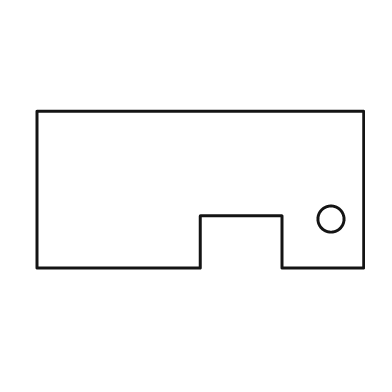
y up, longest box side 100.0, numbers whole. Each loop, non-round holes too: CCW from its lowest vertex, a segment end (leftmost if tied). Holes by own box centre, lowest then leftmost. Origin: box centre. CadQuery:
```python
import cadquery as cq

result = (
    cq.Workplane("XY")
    .moveTo(-50.0, -24.0)
    .lineTo(0.0, -24.0)
    .lineTo(0.0, -8.0)
    .lineTo(25.0, -8.0)
    .lineTo(25.0, -24.0)
    .lineTo(50.0, -24.0)
    .lineTo(50.0, 24.0)
    .lineTo(-50.0, 24.0)
    .close()
    .moveTo(40.0, -9.0)
    .circle(4.0)
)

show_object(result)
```